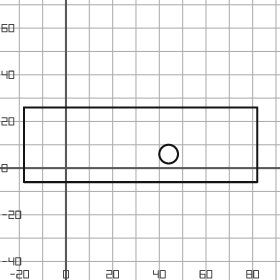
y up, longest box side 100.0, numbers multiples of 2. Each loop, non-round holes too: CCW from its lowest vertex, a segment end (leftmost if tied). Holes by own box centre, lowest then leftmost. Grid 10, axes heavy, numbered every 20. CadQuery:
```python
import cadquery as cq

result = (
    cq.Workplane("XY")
    .moveTo(-18.0, -6.0)
    .lineTo(82.0, -6.0)
    .lineTo(82.0, 26.0)
    .lineTo(-18.0, 26.0)
    .close()
    .moveTo(44.0, 6.0)
    .circle(4.0)
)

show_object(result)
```